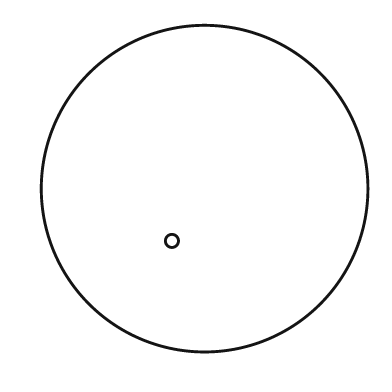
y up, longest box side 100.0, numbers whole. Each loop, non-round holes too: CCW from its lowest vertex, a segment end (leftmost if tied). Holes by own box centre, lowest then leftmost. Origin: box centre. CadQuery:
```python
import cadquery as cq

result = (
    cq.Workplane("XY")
    .moveTo(0.0, 0.0)
    .circle(50.0)
    .moveTo(-10.0, -16.0)
    .circle(2.0)
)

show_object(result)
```